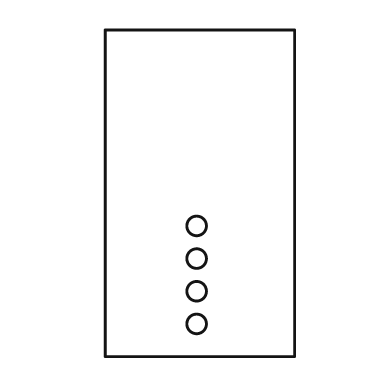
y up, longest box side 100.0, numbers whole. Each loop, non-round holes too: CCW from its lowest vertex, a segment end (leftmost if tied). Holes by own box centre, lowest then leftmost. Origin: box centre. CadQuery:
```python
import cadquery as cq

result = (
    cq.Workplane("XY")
    .moveTo(-29.0, -50.0)
    .lineTo(29.0, -50.0)
    .lineTo(29.0, 50.0)
    .lineTo(-29.0, 50.0)
    .close()
    .moveTo(-1.0, -40.0)
    .circle(3.0)
    .moveTo(-1.0, -30.0)
    .circle(3.0)
    .moveTo(-1.0, -20.0)
    .circle(3.0)
    .moveTo(-1.0, -10.0)
    .circle(3.0)
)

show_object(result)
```